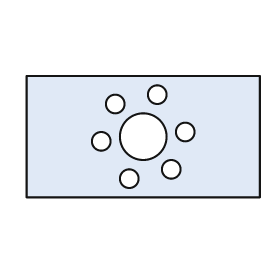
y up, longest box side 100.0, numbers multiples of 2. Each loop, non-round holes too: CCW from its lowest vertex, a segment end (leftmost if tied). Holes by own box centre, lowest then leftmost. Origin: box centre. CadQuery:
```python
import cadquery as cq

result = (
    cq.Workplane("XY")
    .moveTo(-50.0, -26.0)
    .lineTo(50.0, -26.0)
    .lineTo(50.0, 26.0)
    .lineTo(-50.0, 26.0)
    .close()
    .moveTo(-6.0, -18.0)
    .circle(4.0)
    .moveTo(12.0, -14.0)
    .circle(4.0)
    .moveTo(-18.0, -2.0)
    .circle(4.0)
    .moveTo(0.0, 0.0)
    .circle(10.0)
    .moveTo(18.0, 2.0)
    .circle(4.0)
    .moveTo(-12.0, 14.0)
    .circle(4.0)
    .moveTo(6.0, 18.0)
    .circle(4.0)
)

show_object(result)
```